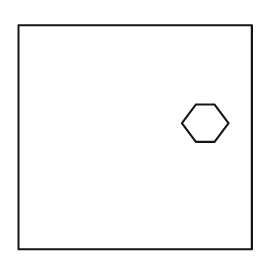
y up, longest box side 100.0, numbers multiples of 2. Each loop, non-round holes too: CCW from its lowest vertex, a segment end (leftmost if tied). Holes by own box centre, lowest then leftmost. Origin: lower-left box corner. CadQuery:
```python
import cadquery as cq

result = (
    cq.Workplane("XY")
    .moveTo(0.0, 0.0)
    .lineTo(100.0, 0.0)
    .lineTo(100.0, 96.0)
    .lineTo(0.0, 96.0)
    .close()
    .moveTo(76.0, 46.0)
    .lineTo(84.0, 46.0)
    .lineTo(90.0, 54.0)
    .lineTo(84.0, 62.0)
    .lineTo(76.0, 62.0)
    .lineTo(70.0, 54.0)
    .close()
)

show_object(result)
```